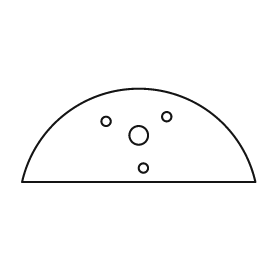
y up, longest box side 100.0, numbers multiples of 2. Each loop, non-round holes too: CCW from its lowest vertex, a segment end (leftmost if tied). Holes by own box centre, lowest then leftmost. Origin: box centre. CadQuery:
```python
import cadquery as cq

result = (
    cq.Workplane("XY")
    .moveTo(-50.0, -20.0)
    .lineTo(50.0, -20.0)
    .threePointArc((0.0, 20.0), (-50.0, -20.0))
    .close()
    .moveTo(2.0, -14.0)
    .circle(2.0)
    .moveTo(0.0, 0.0)
    .circle(4.0)
    .moveTo(-14.0, 6.0)
    .circle(2.0)
    .moveTo(12.0, 8.0)
    .circle(2.0)
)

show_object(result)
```